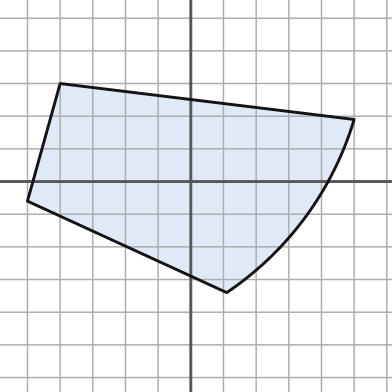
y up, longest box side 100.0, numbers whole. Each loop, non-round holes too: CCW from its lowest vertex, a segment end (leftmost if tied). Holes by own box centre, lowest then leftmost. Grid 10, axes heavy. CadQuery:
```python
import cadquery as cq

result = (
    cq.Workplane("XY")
    .moveTo(11.0, -34.0)
    .threePointArc((35.0, -11.0), (50.0, 19.0))
    .lineTo(-40.0, 30.0)
    .lineTo(-50.0, -6.0)
    .close()
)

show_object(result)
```